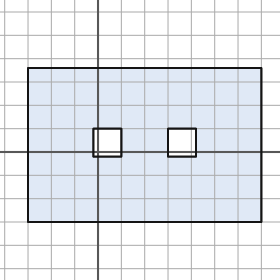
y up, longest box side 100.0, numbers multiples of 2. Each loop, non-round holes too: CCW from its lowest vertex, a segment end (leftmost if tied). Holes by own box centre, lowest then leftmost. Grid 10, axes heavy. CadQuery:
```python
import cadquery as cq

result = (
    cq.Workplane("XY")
    .moveTo(-30.0, -30.0)
    .lineTo(70.0, -30.0)
    .lineTo(70.0, 36.0)
    .lineTo(-30.0, 36.0)
    .close()
    .moveTo(-2.0, -2.0)
    .lineTo(10.0, -2.0)
    .lineTo(10.0, 10.0)
    .lineTo(-2.0, 10.0)
    .close()
    .moveTo(30.0, -2.0)
    .lineTo(42.0, -2.0)
    .lineTo(42.0, 10.0)
    .lineTo(30.0, 10.0)
    .close()
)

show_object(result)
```